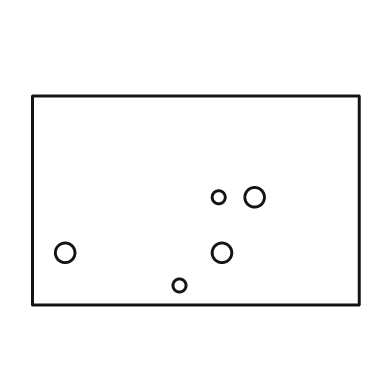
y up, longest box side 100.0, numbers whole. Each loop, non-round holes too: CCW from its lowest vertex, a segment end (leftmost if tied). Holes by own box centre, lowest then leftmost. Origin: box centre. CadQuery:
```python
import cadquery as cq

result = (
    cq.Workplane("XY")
    .moveTo(-50.0, -32.0)
    .lineTo(50.0, -32.0)
    .lineTo(50.0, 32.0)
    .lineTo(-50.0, 32.0)
    .close()
    .moveTo(-5.0, -26.0)
    .circle(2.0)
    .moveTo(-40.0, -16.0)
    .circle(3.0)
    .moveTo(8.0, -16.0)
    .circle(3.0)
    .moveTo(7.0, 1.0)
    .circle(2.0)
    .moveTo(18.0, 1.0)
    .circle(3.0)
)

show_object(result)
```